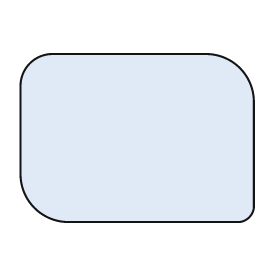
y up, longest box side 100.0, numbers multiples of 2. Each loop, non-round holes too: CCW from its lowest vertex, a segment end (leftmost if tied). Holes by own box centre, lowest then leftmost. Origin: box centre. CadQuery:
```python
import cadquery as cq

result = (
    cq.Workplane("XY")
    .moveTo(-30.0, -36.0)
    .lineTo(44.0, -36.0)
    .threePointArc((48.0, -34.0), (50.0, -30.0))
    .lineTo(50.0, 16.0)
    .threePointArc((44.0, 30.0), (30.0, 36.0))
    .lineTo(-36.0, 36.0)
    .threePointArc((-46.0, 32.0), (-50.0, 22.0))
    .lineTo(-50.0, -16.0)
    .threePointArc((-44.0, -30.0), (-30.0, -36.0))
    .close()
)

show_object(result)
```